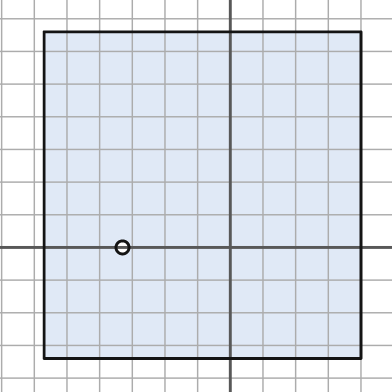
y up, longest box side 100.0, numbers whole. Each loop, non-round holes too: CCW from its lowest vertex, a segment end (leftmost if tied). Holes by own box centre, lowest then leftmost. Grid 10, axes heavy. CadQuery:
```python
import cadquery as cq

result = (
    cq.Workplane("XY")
    .moveTo(-57.0, -34.0)
    .lineTo(40.0, -34.0)
    .lineTo(40.0, 66.0)
    .lineTo(-57.0, 66.0)
    .close()
    .moveTo(-33.0, 0.0)
    .circle(2.0)
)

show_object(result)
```